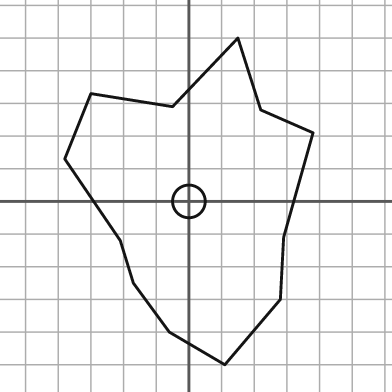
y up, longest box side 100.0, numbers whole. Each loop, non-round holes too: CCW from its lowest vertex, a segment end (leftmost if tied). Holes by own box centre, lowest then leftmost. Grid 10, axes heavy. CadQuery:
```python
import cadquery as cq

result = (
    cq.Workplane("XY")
    .moveTo(11.0, -50.0)
    .lineTo(28.0, -30.0)
    .lineTo(29.0, -11.0)
    .lineTo(38.0, 21.0)
    .lineTo(22.0, 28.0)
    .lineTo(15.0, 50.0)
    .lineTo(-5.0, 29.0)
    .lineTo(-30.0, 33.0)
    .lineTo(-38.0, 13.0)
    .lineTo(-21.0, -12.0)
    .lineTo(-17.0, -25.0)
    .lineTo(-6.0, -40.0)
    .close()
    .moveTo(0.0, 0.0)
    .circle(5.0)
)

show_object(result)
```